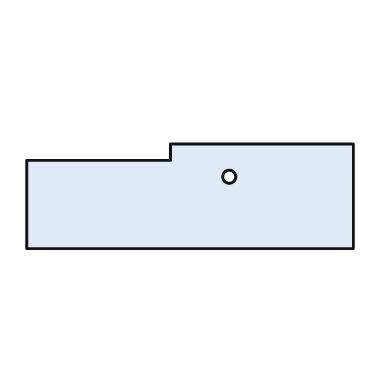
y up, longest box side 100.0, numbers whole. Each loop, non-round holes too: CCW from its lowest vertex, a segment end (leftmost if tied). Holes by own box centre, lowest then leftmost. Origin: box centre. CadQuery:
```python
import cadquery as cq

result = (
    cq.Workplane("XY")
    .moveTo(-50.0, -16.0)
    .lineTo(50.0, -16.0)
    .lineTo(50.0, 16.0)
    .lineTo(-6.0, 16.0)
    .lineTo(-6.0, 11.0)
    .lineTo(-50.0, 11.0)
    .close()
    .moveTo(12.0, 6.0)
    .circle(2.0)
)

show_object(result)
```